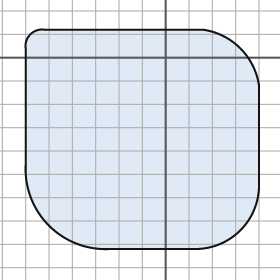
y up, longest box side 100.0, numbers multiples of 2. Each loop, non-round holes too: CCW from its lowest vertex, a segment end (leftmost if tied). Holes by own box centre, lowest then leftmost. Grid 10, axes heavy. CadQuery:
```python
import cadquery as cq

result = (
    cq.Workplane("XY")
    .moveTo(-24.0, -82.0)
    .lineTo(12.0, -82.0)
    .threePointArc((32.0, -74.0), (40.0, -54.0))
    .lineTo(40.0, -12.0)
    .threePointArc((32.0, 4.0), (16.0, 12.0))
    .lineTo(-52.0, 12.0)
    .threePointArc((-58.0, 10.0), (-60.0, 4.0))
    .lineTo(-60.0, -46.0)
    .threePointArc((-50.0, -72.0), (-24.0, -82.0))
    .close()
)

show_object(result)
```